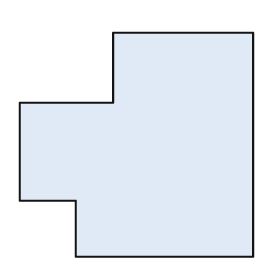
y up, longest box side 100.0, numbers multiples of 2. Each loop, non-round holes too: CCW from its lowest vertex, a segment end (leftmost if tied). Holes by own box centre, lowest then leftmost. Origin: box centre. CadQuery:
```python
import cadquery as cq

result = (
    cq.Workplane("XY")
    .moveTo(-26.0, -48.0)
    .lineTo(50.0, -48.0)
    .lineTo(50.0, 48.0)
    .lineTo(-10.0, 48.0)
    .lineTo(-10.0, 18.0)
    .lineTo(-50.0, 18.0)
    .lineTo(-50.0, -24.0)
    .lineTo(-26.0, -24.0)
    .close()
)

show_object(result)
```